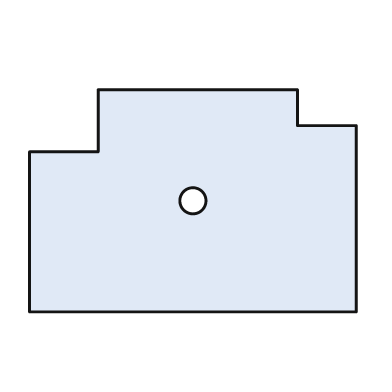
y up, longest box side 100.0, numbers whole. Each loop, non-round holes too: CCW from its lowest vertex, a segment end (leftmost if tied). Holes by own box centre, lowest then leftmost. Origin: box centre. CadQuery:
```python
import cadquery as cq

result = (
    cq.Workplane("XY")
    .moveTo(-50.0, -34.0)
    .lineTo(50.0, -34.0)
    .lineTo(50.0, 23.0)
    .lineTo(32.0, 23.0)
    .lineTo(32.0, 34.0)
    .lineTo(-29.0, 34.0)
    .lineTo(-29.0, 15.0)
    .lineTo(-50.0, 15.0)
    .close()
    .moveTo(0.0, 0.0)
    .circle(4.0)
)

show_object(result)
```